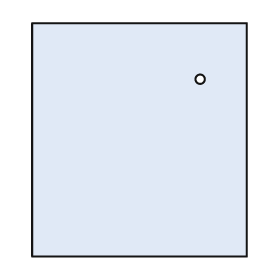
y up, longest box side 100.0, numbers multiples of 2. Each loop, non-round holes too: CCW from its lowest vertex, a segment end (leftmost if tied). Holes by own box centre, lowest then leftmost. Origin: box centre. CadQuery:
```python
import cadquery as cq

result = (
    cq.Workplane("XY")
    .moveTo(-46.0, -50.0)
    .lineTo(46.0, -50.0)
    .lineTo(46.0, 50.0)
    .lineTo(-46.0, 50.0)
    .close()
    .moveTo(26.0, 26.0)
    .circle(2.0)
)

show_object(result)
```